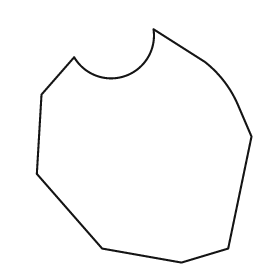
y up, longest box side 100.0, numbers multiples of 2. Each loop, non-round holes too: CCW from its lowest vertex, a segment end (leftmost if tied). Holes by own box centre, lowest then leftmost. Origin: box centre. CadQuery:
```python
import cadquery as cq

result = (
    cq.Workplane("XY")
    .moveTo(16.0, -50.0)
    .lineTo(36.0, -44.0)
    .lineTo(46.0, 4.0)
    .lineTo(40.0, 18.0)
    .threePointArc((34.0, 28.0), (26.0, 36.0))
    .lineTo(4.0, 50.0)
    .threePointArc((-8.0, 30.0), (-30.0, 38.0))
    .lineTo(-44.0, 22.0)
    .lineTo(-46.0, -12.0)
    .lineTo(-18.0, -44.0)
    .close()
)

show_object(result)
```